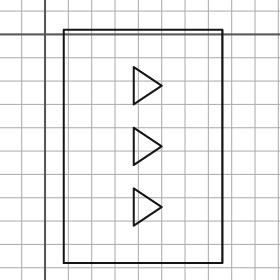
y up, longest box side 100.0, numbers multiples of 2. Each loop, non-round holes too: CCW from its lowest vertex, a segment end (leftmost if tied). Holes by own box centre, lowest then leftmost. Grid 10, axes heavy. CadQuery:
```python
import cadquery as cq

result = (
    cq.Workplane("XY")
    .moveTo(8.0, -98.0)
    .lineTo(76.0, -98.0)
    .lineTo(76.0, 2.0)
    .lineTo(8.0, 2.0)
    .close()
    .moveTo(38.0, -82.0)
    .lineTo(50.0, -74.0)
    .lineTo(38.0, -66.0)
    .close()
    .moveTo(38.0, -56.0)
    .lineTo(50.0, -48.0)
    .lineTo(38.0, -40.0)
    .close()
    .moveTo(38.0, -30.0)
    .lineTo(50.0, -22.0)
    .lineTo(38.0, -14.0)
    .close()
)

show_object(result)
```